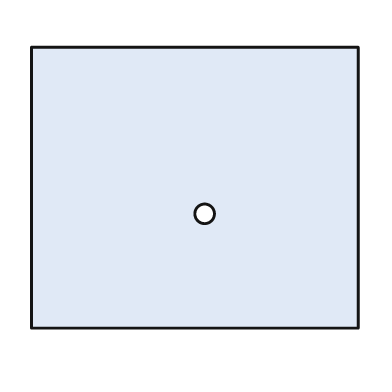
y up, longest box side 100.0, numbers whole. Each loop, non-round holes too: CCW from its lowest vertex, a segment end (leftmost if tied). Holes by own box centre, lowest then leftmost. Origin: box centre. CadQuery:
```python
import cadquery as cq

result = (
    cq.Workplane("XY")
    .moveTo(-50.0, -43.0)
    .lineTo(50.0, -43.0)
    .lineTo(50.0, 43.0)
    .lineTo(-50.0, 43.0)
    .close()
    .moveTo(3.0, -8.0)
    .circle(3.0)
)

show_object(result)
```